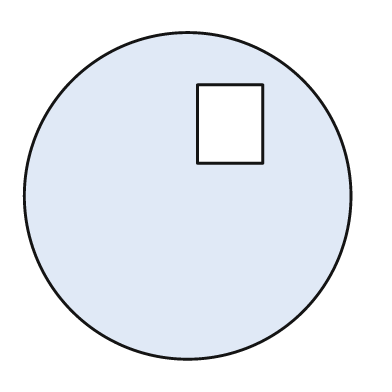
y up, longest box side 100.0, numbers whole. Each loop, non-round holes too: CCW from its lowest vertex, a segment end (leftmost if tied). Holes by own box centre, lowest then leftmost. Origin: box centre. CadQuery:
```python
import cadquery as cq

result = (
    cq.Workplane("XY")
    .moveTo(0.0, 0.0)
    .circle(50.0)
    .moveTo(3.0, 10.0)
    .lineTo(23.0, 10.0)
    .lineTo(23.0, 34.0)
    .lineTo(3.0, 34.0)
    .close()
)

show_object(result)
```